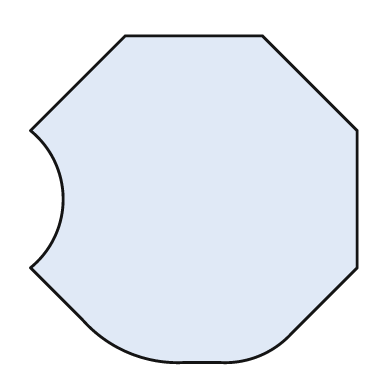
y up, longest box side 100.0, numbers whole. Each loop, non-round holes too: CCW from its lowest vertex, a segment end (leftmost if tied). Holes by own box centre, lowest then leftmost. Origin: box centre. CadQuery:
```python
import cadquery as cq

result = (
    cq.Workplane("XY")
    .moveTo(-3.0, -50.0)
    .lineTo(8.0, -50.0)
    .threePointArc((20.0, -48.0), (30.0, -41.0))
    .lineTo(50.0, -21.0)
    .lineTo(50.0, 21.0)
    .lineTo(21.0, 50.0)
    .lineTo(-21.0, 50.0)
    .lineTo(-50.0, 21.0)
    .threePointArc((-40.0, 0.0), (-50.0, -21.0))
    .lineTo(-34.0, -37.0)
    .threePointArc((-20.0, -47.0), (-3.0, -50.0))
    .close()
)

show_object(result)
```